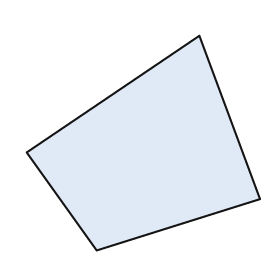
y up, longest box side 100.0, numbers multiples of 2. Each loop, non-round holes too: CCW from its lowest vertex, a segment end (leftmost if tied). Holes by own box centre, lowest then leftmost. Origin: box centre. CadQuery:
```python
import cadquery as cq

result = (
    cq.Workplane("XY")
    .moveTo(-20.0, -46.0)
    .lineTo(50.0, -24.0)
    .lineTo(24.0, 46.0)
    .lineTo(-50.0, -4.0)
    .close()
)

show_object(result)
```